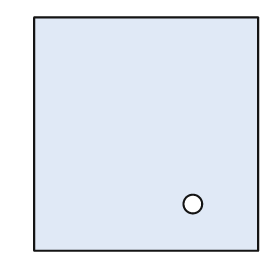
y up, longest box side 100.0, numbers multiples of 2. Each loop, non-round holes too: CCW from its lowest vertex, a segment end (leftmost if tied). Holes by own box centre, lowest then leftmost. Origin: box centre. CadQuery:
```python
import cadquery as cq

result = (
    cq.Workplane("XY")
    .moveTo(-48.0, -50.0)
    .lineTo(48.0, -50.0)
    .lineTo(48.0, 50.0)
    .lineTo(-48.0, 50.0)
    .close()
    .moveTo(20.0, -30.0)
    .circle(4.0)
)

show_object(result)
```